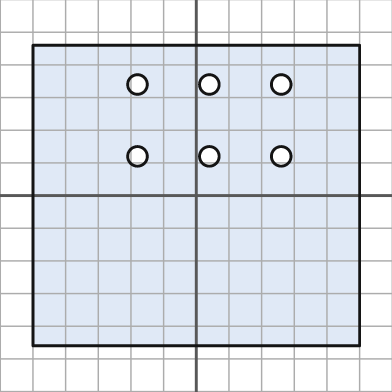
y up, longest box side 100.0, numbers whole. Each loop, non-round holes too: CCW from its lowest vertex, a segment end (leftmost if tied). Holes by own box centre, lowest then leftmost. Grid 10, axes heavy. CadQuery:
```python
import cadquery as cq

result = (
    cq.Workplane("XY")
    .moveTo(-50.0, -46.0)
    .lineTo(50.0, -46.0)
    .lineTo(50.0, 46.0)
    .lineTo(-50.0, 46.0)
    .close()
    .moveTo(-18.0, 12.0)
    .circle(3.0)
    .moveTo(4.0, 12.0)
    .circle(3.0)
    .moveTo(26.0, 12.0)
    .circle(3.0)
    .moveTo(-18.0, 34.0)
    .circle(3.0)
    .moveTo(4.0, 34.0)
    .circle(3.0)
    .moveTo(26.0, 34.0)
    .circle(3.0)
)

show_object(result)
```